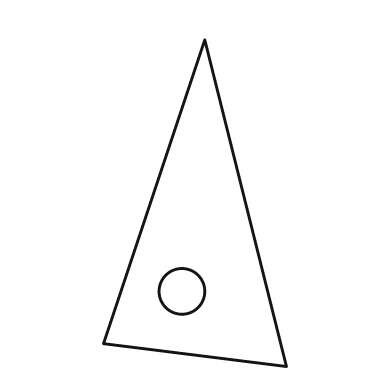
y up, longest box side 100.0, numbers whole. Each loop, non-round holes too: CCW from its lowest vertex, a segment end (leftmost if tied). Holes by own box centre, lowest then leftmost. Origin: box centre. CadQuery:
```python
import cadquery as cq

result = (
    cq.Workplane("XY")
    .moveTo(28.0, -50.0)
    .lineTo(3.0, 50.0)
    .lineTo(-28.0, -43.0)
    .close()
    .moveTo(-4.0, -27.0)
    .circle(7.0)
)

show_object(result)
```